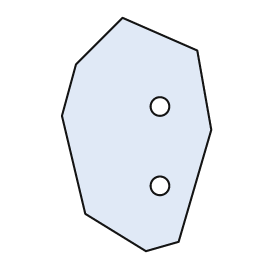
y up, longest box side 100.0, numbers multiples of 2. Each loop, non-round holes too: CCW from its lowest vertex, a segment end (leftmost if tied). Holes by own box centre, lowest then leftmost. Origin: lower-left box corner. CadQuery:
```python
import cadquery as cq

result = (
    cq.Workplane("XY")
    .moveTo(36.0, 0.0)
    .lineTo(50.0, 4.0)
    .lineTo(64.0, 52.0)
    .lineTo(58.0, 86.0)
    .lineTo(26.0, 100.0)
    .lineTo(6.0, 80.0)
    .lineTo(0.0, 58.0)
    .lineTo(10.0, 16.0)
    .close()
    .moveTo(42.0, 28.0)
    .circle(4.0)
    .moveTo(42.0, 62.0)
    .circle(4.0)
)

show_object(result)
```